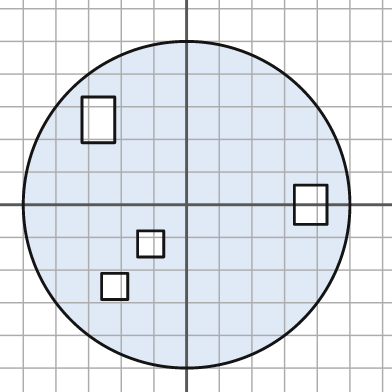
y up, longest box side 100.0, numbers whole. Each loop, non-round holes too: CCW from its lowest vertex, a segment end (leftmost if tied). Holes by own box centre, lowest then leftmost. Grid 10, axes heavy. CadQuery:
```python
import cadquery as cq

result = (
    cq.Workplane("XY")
    .moveTo(0.0, 0.0)
    .circle(50.0)
    .moveTo(-26.0, -29.0)
    .lineTo(-18.0, -29.0)
    .lineTo(-18.0, -21.0)
    .lineTo(-26.0, -21.0)
    .close()
    .moveTo(-15.0, -16.0)
    .lineTo(-7.0, -16.0)
    .lineTo(-7.0, -8.0)
    .lineTo(-15.0, -8.0)
    .close()
    .moveTo(33.0, -6.0)
    .lineTo(43.0, -6.0)
    .lineTo(43.0, 6.0)
    .lineTo(33.0, 6.0)
    .close()
    .moveTo(-32.0, 19.0)
    .lineTo(-22.0, 19.0)
    .lineTo(-22.0, 33.0)
    .lineTo(-32.0, 33.0)
    .close()
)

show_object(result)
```